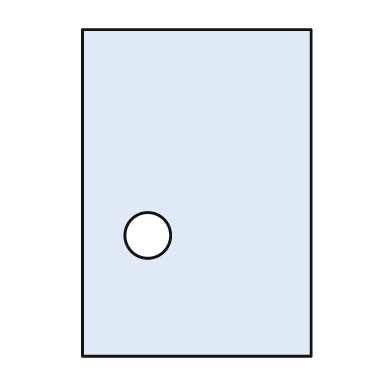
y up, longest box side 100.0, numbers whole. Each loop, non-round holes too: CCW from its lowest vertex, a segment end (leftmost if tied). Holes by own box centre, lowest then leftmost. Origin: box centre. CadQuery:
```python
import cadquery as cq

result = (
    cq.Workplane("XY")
    .moveTo(-35.0, -50.0)
    .lineTo(35.0, -50.0)
    .lineTo(35.0, 50.0)
    .lineTo(-35.0, 50.0)
    .close()
    .moveTo(-15.0, -13.0)
    .circle(7.0)
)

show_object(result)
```